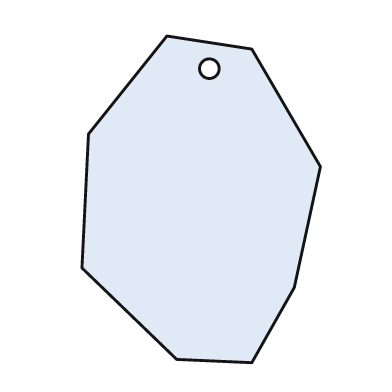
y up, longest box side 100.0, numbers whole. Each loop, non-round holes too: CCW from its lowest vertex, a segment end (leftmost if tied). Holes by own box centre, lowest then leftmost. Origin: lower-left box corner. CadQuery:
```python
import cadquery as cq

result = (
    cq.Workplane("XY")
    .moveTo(52.0, 0.0)
    .lineTo(65.0, 23.0)
    .lineTo(73.0, 60.0)
    .lineTo(52.0, 96.0)
    .lineTo(26.0, 100.0)
    .lineTo(2.0, 70.0)
    .lineTo(0.0, 29.0)
    .lineTo(29.0, 1.0)
    .close()
    .moveTo(39.0, 90.0)
    .circle(3.0)
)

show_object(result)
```